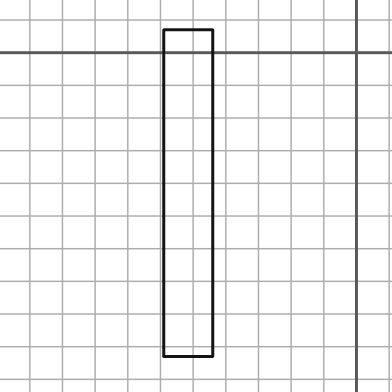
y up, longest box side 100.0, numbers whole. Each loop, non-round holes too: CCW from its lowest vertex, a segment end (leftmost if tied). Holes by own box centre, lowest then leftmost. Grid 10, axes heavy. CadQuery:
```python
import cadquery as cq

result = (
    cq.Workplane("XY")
    .moveTo(-59.0, -93.0)
    .lineTo(-44.0, -93.0)
    .lineTo(-44.0, 7.0)
    .lineTo(-59.0, 7.0)
    .close()
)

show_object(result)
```